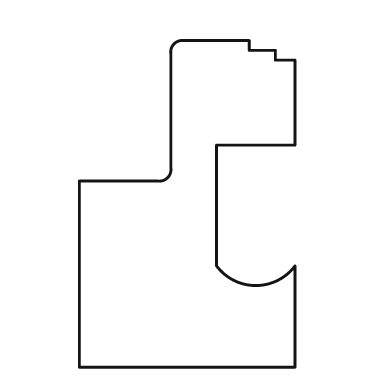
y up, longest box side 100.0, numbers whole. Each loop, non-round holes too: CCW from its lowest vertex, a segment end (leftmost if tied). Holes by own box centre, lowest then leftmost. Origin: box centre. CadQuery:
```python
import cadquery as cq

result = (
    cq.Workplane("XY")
    .moveTo(-33.0, -50.0)
    .lineTo(33.0, -50.0)
    .lineTo(33.0, -19.0)
    .threePointArc((21.0, -25.0), (9.0, -19.0))
    .lineTo(9.0, 18.0)
    .lineTo(33.0, 18.0)
    .lineTo(33.0, 44.0)
    .lineTo(27.0, 44.0)
    .lineTo(27.0, 47.0)
    .lineTo(19.0, 47.0)
    .lineTo(19.0, 50.0)
    .lineTo(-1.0, 50.0)
    .threePointArc((-4.0, 49.0), (-5.0, 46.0))
    .lineTo(-5.0, 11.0)
    .threePointArc((-6.0, 8.0), (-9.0, 7.0))
    .lineTo(-33.0, 7.0)
    .close()
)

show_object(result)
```